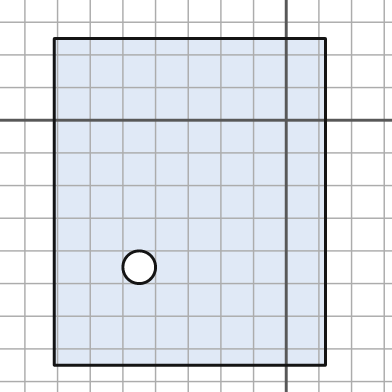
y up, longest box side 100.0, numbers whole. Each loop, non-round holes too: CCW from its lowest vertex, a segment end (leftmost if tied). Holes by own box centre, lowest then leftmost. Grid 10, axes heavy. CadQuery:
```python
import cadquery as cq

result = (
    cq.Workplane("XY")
    .moveTo(-71.0, -75.0)
    .lineTo(12.0, -75.0)
    .lineTo(12.0, 25.0)
    .lineTo(-71.0, 25.0)
    .close()
    .moveTo(-45.0, -45.0)
    .circle(5.0)
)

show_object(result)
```